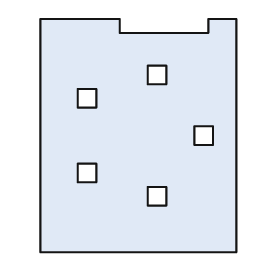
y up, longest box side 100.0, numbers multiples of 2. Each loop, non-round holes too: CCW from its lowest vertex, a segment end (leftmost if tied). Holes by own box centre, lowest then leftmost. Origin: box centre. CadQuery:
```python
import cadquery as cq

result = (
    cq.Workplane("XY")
    .moveTo(-42.0, -50.0)
    .lineTo(42.0, -50.0)
    .lineTo(42.0, 50.0)
    .lineTo(30.0, 50.0)
    .lineTo(30.0, 44.0)
    .lineTo(-8.0, 44.0)
    .lineTo(-8.0, 50.0)
    .lineTo(-42.0, 50.0)
    .close()
    .moveTo(4.0, -30.0)
    .lineTo(12.0, -30.0)
    .lineTo(12.0, -22.0)
    .lineTo(4.0, -22.0)
    .close()
    .moveTo(-26.0, -20.0)
    .lineTo(-18.0, -20.0)
    .lineTo(-18.0, -12.0)
    .lineTo(-26.0, -12.0)
    .close()
    .moveTo(24.0, -4.0)
    .lineTo(32.0, -4.0)
    .lineTo(32.0, 4.0)
    .lineTo(24.0, 4.0)
    .close()
    .moveTo(-26.0, 12.0)
    .lineTo(-18.0, 12.0)
    .lineTo(-18.0, 20.0)
    .lineTo(-26.0, 20.0)
    .close()
    .moveTo(4.0, 22.0)
    .lineTo(12.0, 22.0)
    .lineTo(12.0, 30.0)
    .lineTo(4.0, 30.0)
    .close()
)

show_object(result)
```